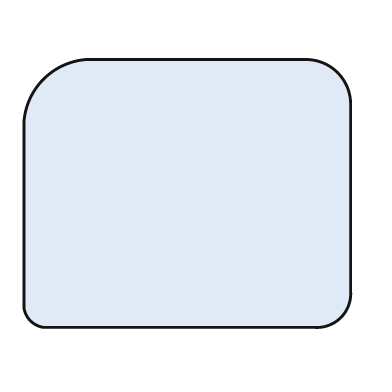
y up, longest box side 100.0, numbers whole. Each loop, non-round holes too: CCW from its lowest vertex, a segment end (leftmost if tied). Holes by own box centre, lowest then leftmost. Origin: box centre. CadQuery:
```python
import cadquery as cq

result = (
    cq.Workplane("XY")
    .moveTo(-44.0, -41.0)
    .lineTo(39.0, -41.0)
    .threePointArc((47.0, -38.0), (50.0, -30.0))
    .lineTo(50.0, 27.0)
    .threePointArc((46.0, 37.0), (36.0, 41.0))
    .lineTo(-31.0, 41.0)
    .threePointArc((-44.0, 35.0), (-50.0, 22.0))
    .lineTo(-50.0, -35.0)
    .threePointArc((-48.0, -39.0), (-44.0, -41.0))
    .close()
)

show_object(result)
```